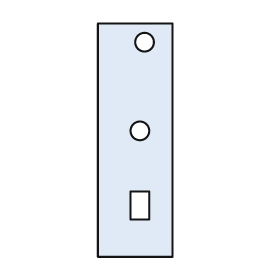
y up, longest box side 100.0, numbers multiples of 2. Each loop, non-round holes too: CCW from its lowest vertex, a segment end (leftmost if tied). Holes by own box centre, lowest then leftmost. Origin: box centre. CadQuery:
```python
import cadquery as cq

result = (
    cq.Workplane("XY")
    .moveTo(-16.0, -50.0)
    .lineTo(16.0, -50.0)
    .lineTo(16.0, 50.0)
    .lineTo(-16.0, 50.0)
    .close()
    .moveTo(-2.0, -34.0)
    .lineTo(6.0, -34.0)
    .lineTo(6.0, -22.0)
    .lineTo(-2.0, -22.0)
    .close()
    .moveTo(2.0, 4.0)
    .circle(4.0)
    .moveTo(4.0, 42.0)
    .circle(4.0)
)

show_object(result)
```